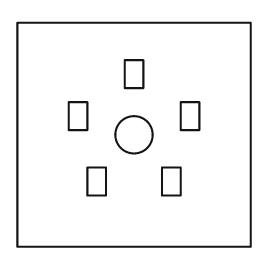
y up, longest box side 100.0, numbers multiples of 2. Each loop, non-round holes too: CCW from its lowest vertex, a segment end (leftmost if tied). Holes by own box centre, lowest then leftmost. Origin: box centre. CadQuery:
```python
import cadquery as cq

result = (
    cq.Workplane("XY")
    .moveTo(-50.0, -48.0)
    .lineTo(50.0, -48.0)
    .lineTo(50.0, 48.0)
    .lineTo(-50.0, 48.0)
    .close()
    .moveTo(-20.0, -26.0)
    .lineTo(-12.0, -26.0)
    .lineTo(-12.0, -14.0)
    .lineTo(-20.0, -14.0)
    .close()
    .moveTo(12.0, -26.0)
    .lineTo(20.0, -26.0)
    .lineTo(20.0, -14.0)
    .lineTo(12.0, -14.0)
    .close()
    .moveTo(0.0, 0.0)
    .circle(8.0)
    .moveTo(-28.0, 2.0)
    .lineTo(-20.0, 2.0)
    .lineTo(-20.0, 14.0)
    .lineTo(-28.0, 14.0)
    .close()
    .moveTo(20.0, 2.0)
    .lineTo(28.0, 2.0)
    .lineTo(28.0, 14.0)
    .lineTo(20.0, 14.0)
    .close()
    .moveTo(-4.0, 20.0)
    .lineTo(4.0, 20.0)
    .lineTo(4.0, 32.0)
    .lineTo(-4.0, 32.0)
    .close()
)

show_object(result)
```